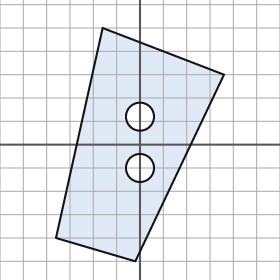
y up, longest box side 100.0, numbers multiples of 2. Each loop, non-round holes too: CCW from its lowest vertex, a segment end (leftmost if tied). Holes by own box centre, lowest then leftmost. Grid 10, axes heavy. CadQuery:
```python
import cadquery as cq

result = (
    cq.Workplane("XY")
    .moveTo(-2.0, -50.0)
    .lineTo(36.0, 30.0)
    .lineTo(-16.0, 50.0)
    .lineTo(-36.0, -40.0)
    .close()
    .moveTo(0.0, -10.0)
    .circle(6.0)
    .moveTo(0.0, 12.0)
    .circle(6.0)
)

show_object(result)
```